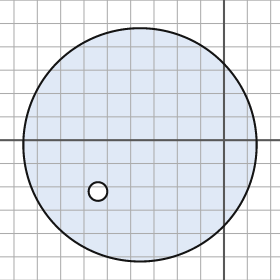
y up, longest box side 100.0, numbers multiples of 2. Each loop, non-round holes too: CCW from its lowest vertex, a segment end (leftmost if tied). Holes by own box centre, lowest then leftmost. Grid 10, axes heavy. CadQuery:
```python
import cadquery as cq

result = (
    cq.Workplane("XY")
    .moveTo(-36.0, -2.0)
    .circle(50.0)
    .moveTo(-54.0, -22.0)
    .circle(4.0)
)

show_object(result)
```